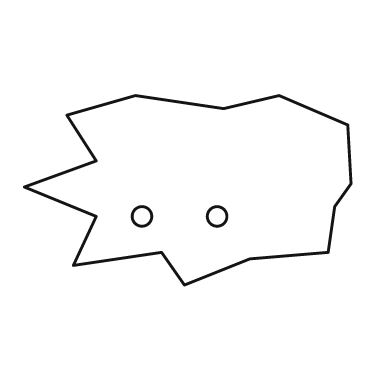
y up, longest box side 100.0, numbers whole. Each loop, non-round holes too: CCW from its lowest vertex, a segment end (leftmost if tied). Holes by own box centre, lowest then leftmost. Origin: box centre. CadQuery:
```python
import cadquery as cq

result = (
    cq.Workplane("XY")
    .moveTo(-1.0, -29.0)
    .lineTo(19.0, -21.0)
    .lineTo(43.0, -19.0)
    .lineTo(45.0, -5.0)
    .lineTo(50.0, 2.0)
    .lineTo(49.0, 20.0)
    .lineTo(28.0, 29.0)
    .lineTo(11.0, 25.0)
    .lineTo(-16.0, 29.0)
    .lineTo(-37.0, 23.0)
    .lineTo(-28.0, 9.0)
    .lineTo(-50.0, 1.0)
    .lineTo(-28.0, -8.0)
    .lineTo(-35.0, -23.0)
    .lineTo(-8.0, -19.0)
    .close()
    .moveTo(-14.0, -8.0)
    .circle(3.0)
    .moveTo(9.0, -8.0)
    .circle(3.0)
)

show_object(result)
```